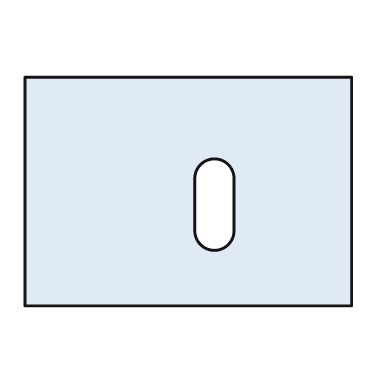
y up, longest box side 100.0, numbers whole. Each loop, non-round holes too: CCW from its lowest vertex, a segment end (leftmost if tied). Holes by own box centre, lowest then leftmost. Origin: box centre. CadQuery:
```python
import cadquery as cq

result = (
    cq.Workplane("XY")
    .moveTo(-50.0, -35.0)
    .lineTo(50.0, -35.0)
    .lineTo(50.0, 35.0)
    .lineTo(-50.0, 35.0)
    .close()
    .moveTo(2.0, -12.0)
    .threePointArc((8.0, -18.0), (14.0, -12.0))
    .lineTo(14.0, 4.0)
    .threePointArc((8.0, 10.0), (2.0, 4.0))
    .close()
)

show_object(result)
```